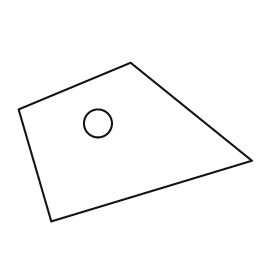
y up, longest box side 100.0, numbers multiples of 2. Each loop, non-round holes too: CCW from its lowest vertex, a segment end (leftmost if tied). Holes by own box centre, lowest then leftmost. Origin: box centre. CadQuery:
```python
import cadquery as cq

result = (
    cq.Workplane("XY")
    .moveTo(-36.0, -34.0)
    .lineTo(50.0, -8.0)
    .lineTo(-2.0, 34.0)
    .lineTo(-50.0, 14.0)
    .close()
    .moveTo(-16.0, 8.0)
    .circle(6.0)
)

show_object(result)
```